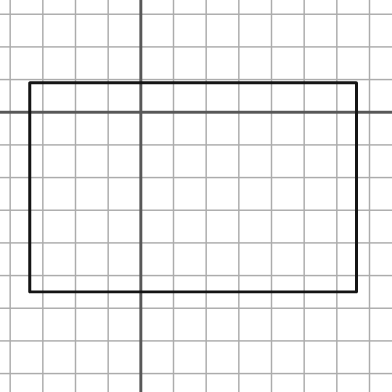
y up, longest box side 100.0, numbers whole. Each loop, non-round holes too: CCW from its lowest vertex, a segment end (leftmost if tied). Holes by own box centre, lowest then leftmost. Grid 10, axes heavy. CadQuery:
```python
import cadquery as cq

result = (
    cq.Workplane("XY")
    .moveTo(-34.0, -55.0)
    .lineTo(66.0, -55.0)
    .lineTo(66.0, 9.0)
    .lineTo(-34.0, 9.0)
    .close()
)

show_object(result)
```